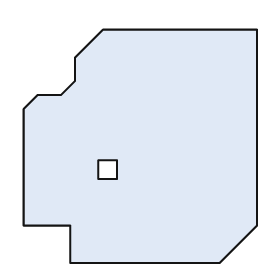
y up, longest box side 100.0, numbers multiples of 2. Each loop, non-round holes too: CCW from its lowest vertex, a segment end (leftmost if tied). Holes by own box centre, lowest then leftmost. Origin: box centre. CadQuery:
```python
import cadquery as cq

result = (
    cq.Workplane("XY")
    .moveTo(-30.0, -50.0)
    .lineTo(34.0, -50.0)
    .lineTo(50.0, -34.0)
    .lineTo(50.0, 50.0)
    .lineTo(-16.0, 50.0)
    .lineTo(-28.0, 38.0)
    .lineTo(-28.0, 28.0)
    .lineTo(-34.0, 22.0)
    .lineTo(-44.0, 22.0)
    .lineTo(-50.0, 16.0)
    .lineTo(-50.0, -34.0)
    .lineTo(-30.0, -34.0)
    .close()
    .moveTo(-18.0, -14.0)
    .lineTo(-10.0, -14.0)
    .lineTo(-10.0, -6.0)
    .lineTo(-18.0, -6.0)
    .close()
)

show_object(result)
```